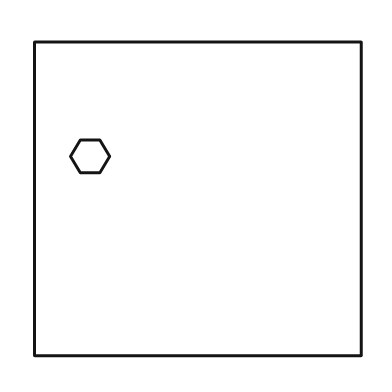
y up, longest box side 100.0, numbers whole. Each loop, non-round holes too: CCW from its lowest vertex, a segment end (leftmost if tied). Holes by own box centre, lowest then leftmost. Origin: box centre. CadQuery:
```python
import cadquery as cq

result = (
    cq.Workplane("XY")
    .moveTo(-50.0, -48.0)
    .lineTo(50.0, -48.0)
    .lineTo(50.0, 48.0)
    .lineTo(-50.0, 48.0)
    .close()
    .moveTo(-36.0, 8.0)
    .lineTo(-30.0, 8.0)
    .lineTo(-27.0, 13.0)
    .lineTo(-30.0, 18.0)
    .lineTo(-36.0, 18.0)
    .lineTo(-39.0, 13.0)
    .close()
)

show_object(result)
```